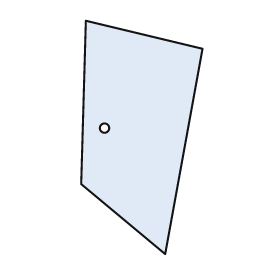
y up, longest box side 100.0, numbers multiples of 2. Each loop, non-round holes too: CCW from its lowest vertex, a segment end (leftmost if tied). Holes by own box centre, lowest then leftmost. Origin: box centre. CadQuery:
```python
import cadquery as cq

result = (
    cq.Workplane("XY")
    .moveTo(10.0, -50.0)
    .lineTo(26.0, 38.0)
    .lineTo(-24.0, 50.0)
    .lineTo(-26.0, -20.0)
    .close()
    .moveTo(-16.0, 4.0)
    .circle(2.0)
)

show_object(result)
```